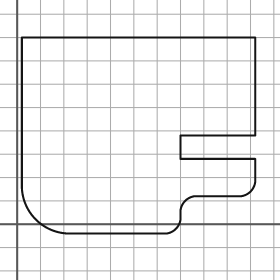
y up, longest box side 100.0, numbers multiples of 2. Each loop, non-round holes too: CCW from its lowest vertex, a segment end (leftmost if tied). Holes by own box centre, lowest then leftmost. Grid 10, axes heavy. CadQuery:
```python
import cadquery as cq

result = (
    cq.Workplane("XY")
    .moveTo(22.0, -4.0)
    .lineTo(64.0, -4.0)
    .threePointArc((68.0, -2.0), (70.0, 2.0))
    .lineTo(70.0, 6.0)
    .threePointArc((72.0, 10.0), (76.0, 12.0))
    .lineTo(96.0, 12.0)
    .threePointArc((100.0, 14.0), (102.0, 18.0))
    .lineTo(102.0, 28.0)
    .lineTo(70.0, 28.0)
    .lineTo(70.0, 38.0)
    .lineTo(102.0, 38.0)
    .lineTo(102.0, 80.0)
    .lineTo(2.0, 80.0)
    .lineTo(2.0, 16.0)
    .threePointArc((8.0, 2.0), (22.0, -4.0))
    .close()
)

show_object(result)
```